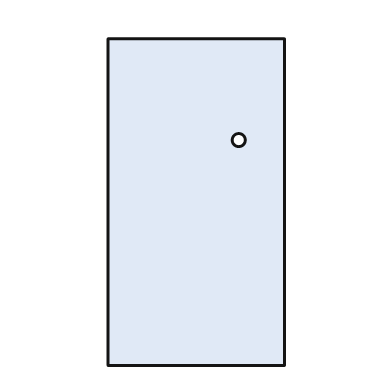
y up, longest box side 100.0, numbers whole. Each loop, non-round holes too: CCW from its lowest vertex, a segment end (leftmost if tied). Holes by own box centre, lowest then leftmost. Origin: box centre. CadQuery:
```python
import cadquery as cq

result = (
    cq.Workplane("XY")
    .moveTo(-27.0, -50.0)
    .lineTo(27.0, -50.0)
    .lineTo(27.0, 50.0)
    .lineTo(-27.0, 50.0)
    .close()
    .moveTo(13.0, 19.0)
    .circle(2.0)
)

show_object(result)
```